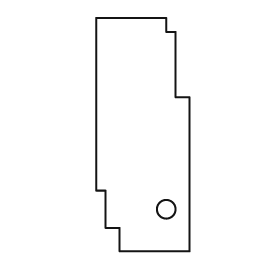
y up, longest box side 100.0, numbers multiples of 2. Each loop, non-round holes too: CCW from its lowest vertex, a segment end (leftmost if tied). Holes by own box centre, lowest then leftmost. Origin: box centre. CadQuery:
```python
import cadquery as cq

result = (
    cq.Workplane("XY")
    .moveTo(-10.0, -50.0)
    .lineTo(20.0, -50.0)
    .lineTo(20.0, 16.0)
    .lineTo(14.0, 16.0)
    .lineTo(14.0, 44.0)
    .lineTo(10.0, 44.0)
    .lineTo(10.0, 50.0)
    .lineTo(-20.0, 50.0)
    .lineTo(-20.0, -24.0)
    .lineTo(-16.0, -24.0)
    .lineTo(-16.0, -40.0)
    .lineTo(-10.0, -40.0)
    .close()
    .moveTo(10.0, -32.0)
    .circle(4.0)
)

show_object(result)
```